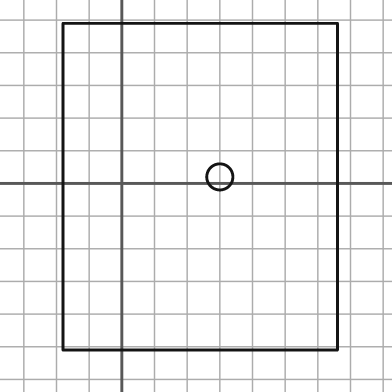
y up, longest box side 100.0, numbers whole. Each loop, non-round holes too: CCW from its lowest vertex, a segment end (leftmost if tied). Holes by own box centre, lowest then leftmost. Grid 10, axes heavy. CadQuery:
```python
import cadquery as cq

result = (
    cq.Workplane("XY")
    .moveTo(-18.0, -51.0)
    .lineTo(66.0, -51.0)
    .lineTo(66.0, 49.0)
    .lineTo(-18.0, 49.0)
    .close()
    .moveTo(30.0, 2.0)
    .circle(4.0)
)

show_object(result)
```